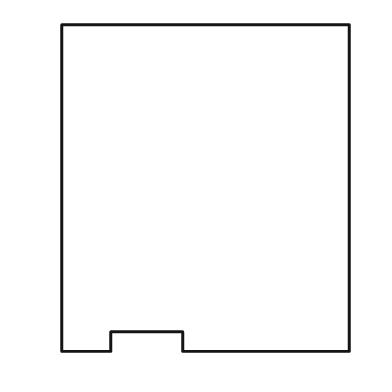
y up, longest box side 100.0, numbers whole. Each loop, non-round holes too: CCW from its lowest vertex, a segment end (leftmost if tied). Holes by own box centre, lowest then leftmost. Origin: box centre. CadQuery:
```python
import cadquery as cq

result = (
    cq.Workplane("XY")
    .moveTo(-44.0, -50.0)
    .lineTo(-29.0, -50.0)
    .lineTo(-29.0, -44.0)
    .lineTo(-7.0, -44.0)
    .lineTo(-7.0, -50.0)
    .lineTo(44.0, -50.0)
    .lineTo(44.0, 50.0)
    .lineTo(-44.0, 50.0)
    .close()
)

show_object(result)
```